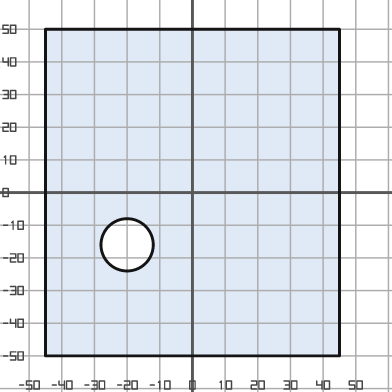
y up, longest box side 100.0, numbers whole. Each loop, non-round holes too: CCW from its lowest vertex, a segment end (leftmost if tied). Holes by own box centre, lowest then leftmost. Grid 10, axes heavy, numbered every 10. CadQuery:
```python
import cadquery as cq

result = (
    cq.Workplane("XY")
    .moveTo(-45.0, -50.0)
    .lineTo(45.0, -50.0)
    .lineTo(45.0, 50.0)
    .lineTo(-45.0, 50.0)
    .close()
    .moveTo(-20.0, -16.0)
    .circle(8.0)
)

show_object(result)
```